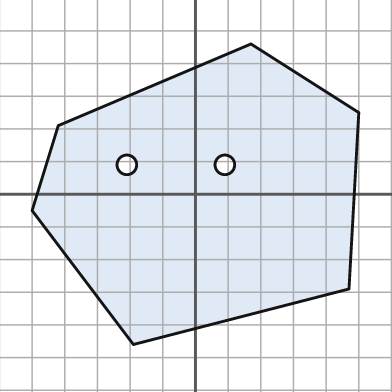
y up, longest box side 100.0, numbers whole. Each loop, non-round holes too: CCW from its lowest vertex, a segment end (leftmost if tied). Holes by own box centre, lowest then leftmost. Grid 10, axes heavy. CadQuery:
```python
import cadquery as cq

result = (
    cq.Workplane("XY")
    .moveTo(-19.0, -46.0)
    .lineTo(47.0, -29.0)
    .lineTo(50.0, 25.0)
    .lineTo(17.0, 46.0)
    .lineTo(-42.0, 21.0)
    .lineTo(-50.0, -5.0)
    .close()
    .moveTo(-21.0, 9.0)
    .circle(3.0)
    .moveTo(9.0, 9.0)
    .circle(3.0)
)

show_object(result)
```